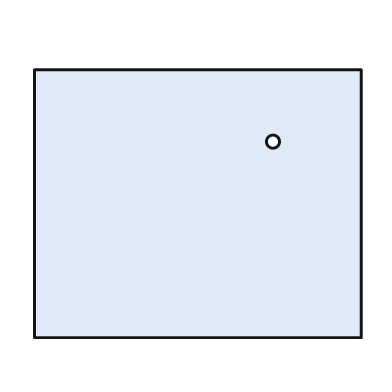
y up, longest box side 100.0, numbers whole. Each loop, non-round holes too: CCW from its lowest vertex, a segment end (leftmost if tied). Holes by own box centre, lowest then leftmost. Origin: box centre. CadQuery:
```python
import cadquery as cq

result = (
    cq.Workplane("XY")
    .moveTo(-50.0, -41.0)
    .lineTo(50.0, -41.0)
    .lineTo(50.0, 41.0)
    .lineTo(-50.0, 41.0)
    .close()
    .moveTo(23.0, 19.0)
    .circle(2.0)
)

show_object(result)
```